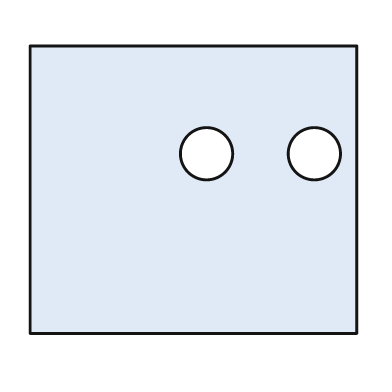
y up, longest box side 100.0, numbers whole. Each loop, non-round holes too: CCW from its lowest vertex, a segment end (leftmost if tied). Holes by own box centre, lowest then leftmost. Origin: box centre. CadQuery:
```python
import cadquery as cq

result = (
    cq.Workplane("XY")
    .moveTo(-50.0, -44.0)
    .lineTo(50.0, -44.0)
    .lineTo(50.0, 44.0)
    .lineTo(-50.0, 44.0)
    .close()
    .moveTo(4.0, 11.0)
    .circle(8.0)
    .moveTo(37.0, 11.0)
    .circle(8.0)
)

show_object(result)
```